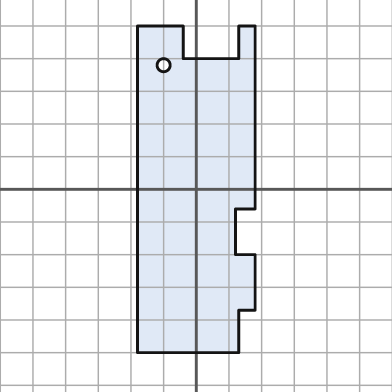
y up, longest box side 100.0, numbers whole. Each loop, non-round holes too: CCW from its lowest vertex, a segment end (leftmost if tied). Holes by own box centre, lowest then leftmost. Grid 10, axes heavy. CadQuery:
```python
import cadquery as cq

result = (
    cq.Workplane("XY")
    .moveTo(-18.0, -50.0)
    .lineTo(13.0, -50.0)
    .lineTo(13.0, -37.0)
    .lineTo(18.0, -37.0)
    .lineTo(18.0, -20.0)
    .lineTo(12.0, -20.0)
    .lineTo(12.0, -6.0)
    .lineTo(18.0, -6.0)
    .lineTo(18.0, 50.0)
    .lineTo(13.0, 50.0)
    .lineTo(13.0, 40.0)
    .lineTo(-4.0, 40.0)
    .lineTo(-4.0, 50.0)
    .lineTo(-18.0, 50.0)
    .close()
    .moveTo(-10.0, 38.0)
    .circle(2.0)
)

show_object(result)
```